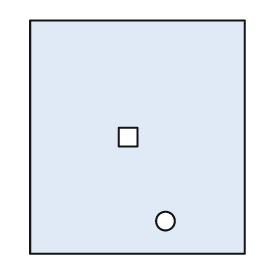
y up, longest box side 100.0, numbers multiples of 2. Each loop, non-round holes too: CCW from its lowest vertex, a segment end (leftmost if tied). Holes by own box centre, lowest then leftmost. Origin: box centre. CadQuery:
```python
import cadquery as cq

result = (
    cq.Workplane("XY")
    .moveTo(-46.0, -50.0)
    .lineTo(46.0, -50.0)
    .lineTo(46.0, 50.0)
    .lineTo(-46.0, 50.0)
    .close()
    .moveTo(12.0, -36.0)
    .circle(4.0)
    .moveTo(-8.0, -4.0)
    .lineTo(0.0, -4.0)
    .lineTo(0.0, 4.0)
    .lineTo(-8.0, 4.0)
    .close()
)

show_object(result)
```